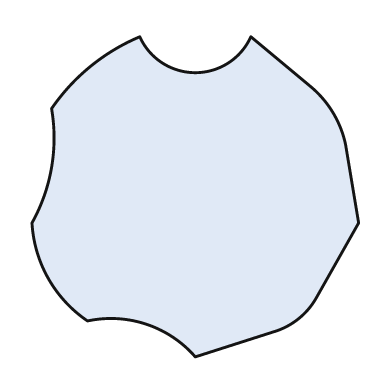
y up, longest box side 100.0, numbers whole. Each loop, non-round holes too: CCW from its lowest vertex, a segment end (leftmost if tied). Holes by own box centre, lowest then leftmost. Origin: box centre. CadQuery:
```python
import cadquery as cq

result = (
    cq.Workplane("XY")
    .moveTo(0.0, -49.0)
    .lineTo(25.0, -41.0)
    .threePointArc((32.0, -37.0), (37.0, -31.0))
    .lineTo(50.0, -8.0)
    .lineTo(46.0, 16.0)
    .threePointArc((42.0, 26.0), (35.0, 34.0))
    .lineTo(17.0, 49.0)
    .threePointArc((0.0, 38.0), (-17.0, 49.0))
    .threePointArc((-32.0, 40.0), (-44.0, 27.0))
    .threePointArc((-44.0, 9.0), (-50.0, -8.0))
    .threePointArc((-45.0, -25.0), (-33.0, -38.0))
    .threePointArc((-15.0, -39.0), (0.0, -49.0))
    .close()
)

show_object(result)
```